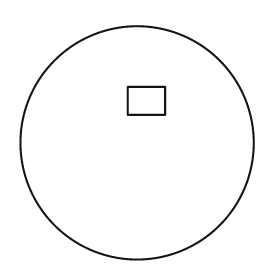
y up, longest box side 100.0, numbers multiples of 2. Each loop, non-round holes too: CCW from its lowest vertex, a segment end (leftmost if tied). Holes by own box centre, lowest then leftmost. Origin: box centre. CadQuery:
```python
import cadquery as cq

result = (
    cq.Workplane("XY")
    .moveTo(0.0, 0.0)
    .circle(50.0)
    .moveTo(-4.0, 12.0)
    .lineTo(12.0, 12.0)
    .lineTo(12.0, 24.0)
    .lineTo(-4.0, 24.0)
    .close()
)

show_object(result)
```